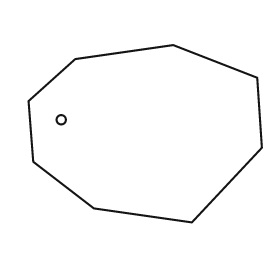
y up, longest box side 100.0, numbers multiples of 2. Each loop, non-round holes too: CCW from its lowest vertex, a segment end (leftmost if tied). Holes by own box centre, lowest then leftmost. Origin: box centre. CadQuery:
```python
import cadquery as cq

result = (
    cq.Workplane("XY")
    .moveTo(20.0, -38.0)
    .lineTo(50.0, -6.0)
    .lineTo(48.0, 24.0)
    .lineTo(12.0, 38.0)
    .lineTo(-30.0, 32.0)
    .lineTo(-50.0, 14.0)
    .lineTo(-48.0, -12.0)
    .lineTo(-22.0, -32.0)
    .close()
    .moveTo(-36.0, 6.0)
    .circle(2.0)
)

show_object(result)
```